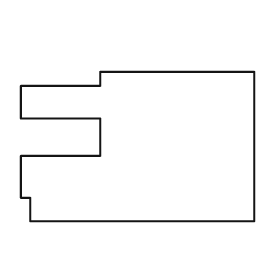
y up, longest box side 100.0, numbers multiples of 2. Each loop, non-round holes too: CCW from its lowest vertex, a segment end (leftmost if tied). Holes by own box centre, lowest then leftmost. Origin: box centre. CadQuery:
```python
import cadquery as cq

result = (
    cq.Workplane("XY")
    .moveTo(-46.0, -32.0)
    .lineTo(50.0, -32.0)
    .lineTo(50.0, 32.0)
    .lineTo(-16.0, 32.0)
    .lineTo(-16.0, 26.0)
    .lineTo(-50.0, 26.0)
    .lineTo(-50.0, 12.0)
    .lineTo(-16.0, 12.0)
    .lineTo(-16.0, -4.0)
    .lineTo(-50.0, -4.0)
    .lineTo(-50.0, -22.0)
    .lineTo(-46.0, -22.0)
    .close()
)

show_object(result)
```